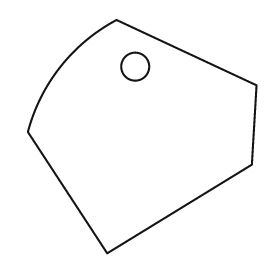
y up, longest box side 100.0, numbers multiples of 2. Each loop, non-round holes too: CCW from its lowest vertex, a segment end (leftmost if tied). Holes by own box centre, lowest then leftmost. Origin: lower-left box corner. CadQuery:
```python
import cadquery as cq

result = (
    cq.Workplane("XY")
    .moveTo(34.0, 0.0)
    .lineTo(96.0, 38.0)
    .lineTo(98.0, 72.0)
    .lineTo(38.0, 100.0)
    .threePointArc((14.0, 80.0), (0.0, 52.0))
    .close()
    .moveTo(46.0, 80.0)
    .circle(6.0)
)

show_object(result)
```